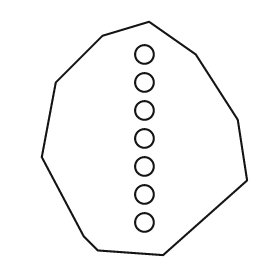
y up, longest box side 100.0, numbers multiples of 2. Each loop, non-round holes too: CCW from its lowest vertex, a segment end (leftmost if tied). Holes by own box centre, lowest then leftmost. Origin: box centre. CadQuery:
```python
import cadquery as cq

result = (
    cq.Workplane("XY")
    .moveTo(8.0, -50.0)
    .lineTo(44.0, -18.0)
    .lineTo(40.0, 8.0)
    .lineTo(22.0, 36.0)
    .lineTo(2.0, 50.0)
    .lineTo(-18.0, 44.0)
    .lineTo(-38.0, 24.0)
    .lineTo(-44.0, -8.0)
    .lineTo(-26.0, -42.0)
    .lineTo(-20.0, -48.0)
    .close()
    .moveTo(0.0, -36.0)
    .circle(4.0)
    .moveTo(0.0, -24.0)
    .circle(4.0)
    .moveTo(0.0, -12.0)
    .circle(4.0)
    .moveTo(0.0, 0.0)
    .circle(4.0)
    .moveTo(0.0, 12.0)
    .circle(4.0)
    .moveTo(0.0, 24.0)
    .circle(4.0)
    .moveTo(0.0, 36.0)
    .circle(4.0)
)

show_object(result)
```